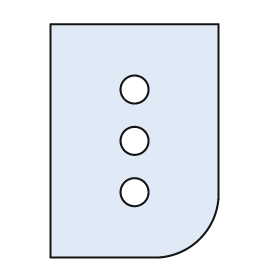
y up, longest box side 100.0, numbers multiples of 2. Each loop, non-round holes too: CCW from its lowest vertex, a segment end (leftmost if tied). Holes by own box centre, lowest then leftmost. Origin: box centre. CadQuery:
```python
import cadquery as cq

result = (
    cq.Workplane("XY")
    .moveTo(-36.0, -50.0)
    .lineTo(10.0, -50.0)
    .threePointArc((28.0, -42.0), (36.0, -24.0))
    .lineTo(36.0, 50.0)
    .lineTo(-36.0, 50.0)
    .close()
    .moveTo(0.0, -22.0)
    .circle(6.0)
    .moveTo(0.0, 0.0)
    .circle(6.0)
    .moveTo(0.0, 22.0)
    .circle(6.0)
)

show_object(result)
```